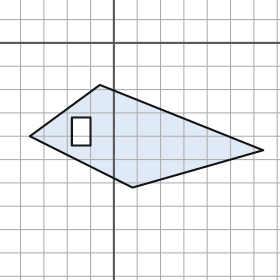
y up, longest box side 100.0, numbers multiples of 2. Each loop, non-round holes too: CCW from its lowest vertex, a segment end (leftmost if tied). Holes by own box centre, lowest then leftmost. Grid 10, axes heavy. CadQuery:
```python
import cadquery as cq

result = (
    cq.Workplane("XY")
    .moveTo(8.0, -62.0)
    .lineTo(64.0, -46.0)
    .lineTo(-6.0, -18.0)
    .lineTo(-36.0, -40.0)
    .close()
    .moveTo(-18.0, -44.0)
    .lineTo(-10.0, -44.0)
    .lineTo(-10.0, -32.0)
    .lineTo(-18.0, -32.0)
    .close()
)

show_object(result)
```